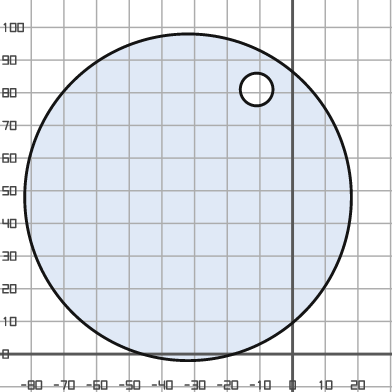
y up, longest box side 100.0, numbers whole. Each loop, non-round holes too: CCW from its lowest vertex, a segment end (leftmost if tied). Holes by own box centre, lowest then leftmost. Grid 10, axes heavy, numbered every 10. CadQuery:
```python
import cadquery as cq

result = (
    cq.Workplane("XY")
    .moveTo(-32.0, 48.0)
    .circle(50.0)
    .moveTo(-11.0, 81.0)
    .circle(5.0)
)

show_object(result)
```